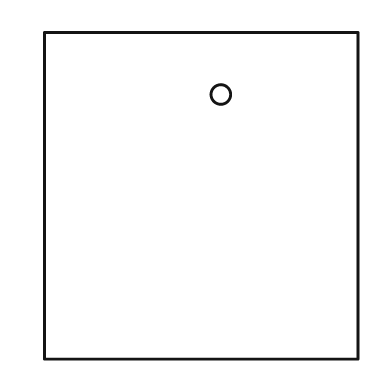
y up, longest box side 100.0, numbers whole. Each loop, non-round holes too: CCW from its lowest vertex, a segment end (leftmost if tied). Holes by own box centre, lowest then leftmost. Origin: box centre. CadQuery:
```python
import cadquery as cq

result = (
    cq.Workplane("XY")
    .moveTo(-48.0, -50.0)
    .lineTo(48.0, -50.0)
    .lineTo(48.0, 50.0)
    .lineTo(-48.0, 50.0)
    .close()
    .moveTo(6.0, 31.0)
    .circle(3.0)
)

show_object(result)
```